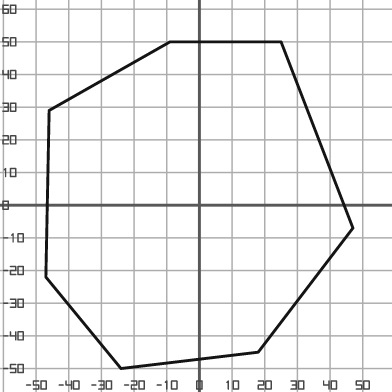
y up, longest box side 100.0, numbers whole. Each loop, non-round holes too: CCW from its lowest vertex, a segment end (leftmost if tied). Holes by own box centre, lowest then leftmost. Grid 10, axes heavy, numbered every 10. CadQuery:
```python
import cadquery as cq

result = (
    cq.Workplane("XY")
    .moveTo(-24.0, -50.0)
    .lineTo(18.0, -45.0)
    .lineTo(47.0, -7.0)
    .lineTo(25.0, 50.0)
    .lineTo(-9.0, 50.0)
    .lineTo(-46.0, 29.0)
    .lineTo(-47.0, -22.0)
    .close()
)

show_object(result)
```